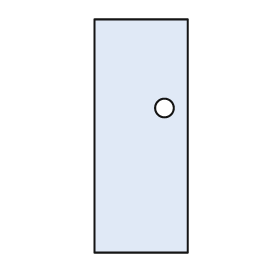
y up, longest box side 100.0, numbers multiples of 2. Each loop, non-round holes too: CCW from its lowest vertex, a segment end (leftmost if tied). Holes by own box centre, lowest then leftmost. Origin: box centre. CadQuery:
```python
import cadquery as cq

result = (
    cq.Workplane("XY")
    .moveTo(-20.0, -50.0)
    .lineTo(20.0, -50.0)
    .lineTo(20.0, 50.0)
    .lineTo(-20.0, 50.0)
    .close()
    .moveTo(10.0, 12.0)
    .circle(4.0)
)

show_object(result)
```